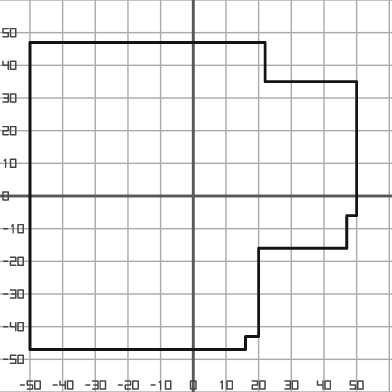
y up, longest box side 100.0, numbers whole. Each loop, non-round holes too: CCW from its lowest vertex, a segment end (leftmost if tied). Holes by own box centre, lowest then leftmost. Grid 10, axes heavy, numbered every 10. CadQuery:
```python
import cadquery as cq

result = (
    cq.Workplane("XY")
    .moveTo(-50.0, -47.0)
    .lineTo(16.0, -47.0)
    .lineTo(16.0, -43.0)
    .lineTo(20.0, -43.0)
    .lineTo(20.0, -16.0)
    .lineTo(47.0, -16.0)
    .lineTo(47.0, -6.0)
    .lineTo(50.0, -6.0)
    .lineTo(50.0, 35.0)
    .lineTo(22.0, 35.0)
    .lineTo(22.0, 47.0)
    .lineTo(-50.0, 47.0)
    .close()
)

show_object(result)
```